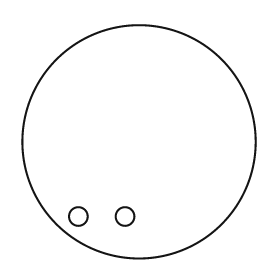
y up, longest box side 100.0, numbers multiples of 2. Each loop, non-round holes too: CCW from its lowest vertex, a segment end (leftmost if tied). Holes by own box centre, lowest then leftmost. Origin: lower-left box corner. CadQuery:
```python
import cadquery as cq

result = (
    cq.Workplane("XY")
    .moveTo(50.0, 50.0)
    .circle(50.0)
    .moveTo(24.0, 18.0)
    .circle(4.0)
    .moveTo(44.0, 18.0)
    .circle(4.0)
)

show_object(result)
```